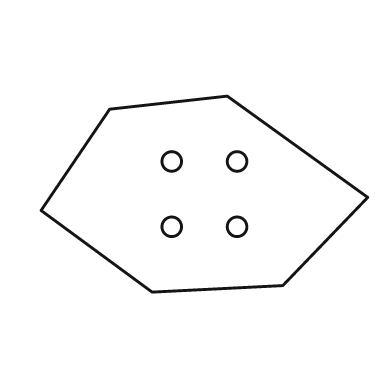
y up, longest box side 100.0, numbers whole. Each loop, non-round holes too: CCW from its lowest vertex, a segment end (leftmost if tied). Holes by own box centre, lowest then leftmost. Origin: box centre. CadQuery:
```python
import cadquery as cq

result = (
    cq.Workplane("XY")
    .moveTo(-16.0, -30.0)
    .lineTo(24.0, -28.0)
    .lineTo(50.0, -1.0)
    .lineTo(7.0, 30.0)
    .lineTo(-29.0, 26.0)
    .lineTo(-50.0, -5.0)
    .close()
    .moveTo(-10.0, -10.0)
    .circle(3.0)
    .moveTo(10.0, -10.0)
    .circle(3.0)
    .moveTo(-10.0, 10.0)
    .circle(3.0)
    .moveTo(10.0, 10.0)
    .circle(3.0)
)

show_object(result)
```